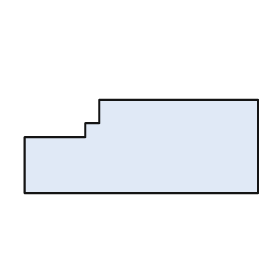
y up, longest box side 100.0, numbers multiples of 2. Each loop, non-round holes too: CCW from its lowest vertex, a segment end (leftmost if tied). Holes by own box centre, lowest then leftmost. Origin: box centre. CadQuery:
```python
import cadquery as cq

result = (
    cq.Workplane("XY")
    .moveTo(-50.0, -20.0)
    .lineTo(50.0, -20.0)
    .lineTo(50.0, 20.0)
    .lineTo(-18.0, 20.0)
    .lineTo(-18.0, 10.0)
    .lineTo(-24.0, 10.0)
    .lineTo(-24.0, 4.0)
    .lineTo(-50.0, 4.0)
    .close()
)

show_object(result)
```